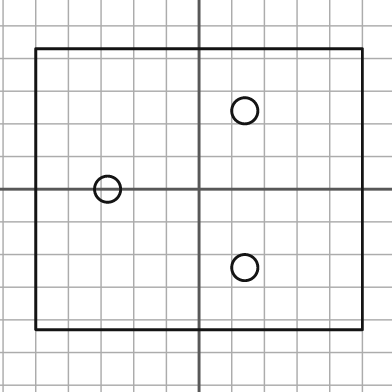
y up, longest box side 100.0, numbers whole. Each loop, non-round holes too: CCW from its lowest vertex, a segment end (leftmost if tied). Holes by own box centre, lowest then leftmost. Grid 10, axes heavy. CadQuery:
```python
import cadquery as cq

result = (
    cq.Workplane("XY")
    .moveTo(-50.0, -43.0)
    .lineTo(50.0, -43.0)
    .lineTo(50.0, 43.0)
    .lineTo(-50.0, 43.0)
    .close()
    .moveTo(14.0, -24.0)
    .circle(4.0)
    .moveTo(-28.0, 0.0)
    .circle(4.0)
    .moveTo(14.0, 24.0)
    .circle(4.0)
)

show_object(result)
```